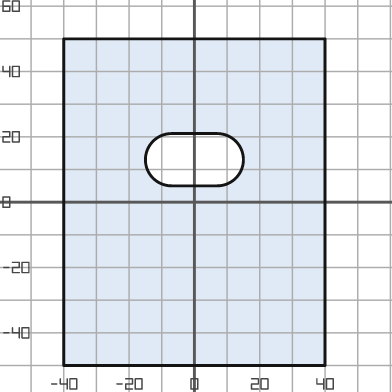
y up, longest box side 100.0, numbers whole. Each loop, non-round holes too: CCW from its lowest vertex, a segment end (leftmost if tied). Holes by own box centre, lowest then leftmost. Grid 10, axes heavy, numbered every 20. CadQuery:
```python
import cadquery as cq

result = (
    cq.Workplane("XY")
    .moveTo(-40.0, -50.0)
    .lineTo(40.0, -50.0)
    .lineTo(40.0, 50.0)
    .lineTo(-40.0, 50.0)
    .close()
    .moveTo(-7.0, 5.0)
    .lineTo(7.0, 5.0)
    .threePointArc((15.0, 13.0), (7.0, 21.0))
    .lineTo(-7.0, 21.0)
    .threePointArc((-15.0, 13.0), (-7.0, 5.0))
    .close()
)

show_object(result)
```